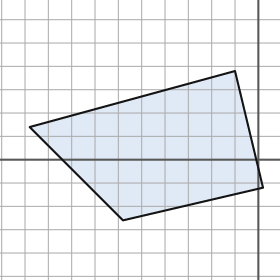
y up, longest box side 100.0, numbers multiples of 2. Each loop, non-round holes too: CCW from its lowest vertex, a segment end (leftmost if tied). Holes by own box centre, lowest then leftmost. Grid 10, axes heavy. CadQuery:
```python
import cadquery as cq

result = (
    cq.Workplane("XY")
    .moveTo(-58.0, -26.0)
    .lineTo(2.0, -12.0)
    .lineTo(-10.0, 38.0)
    .lineTo(-98.0, 14.0)
    .close()
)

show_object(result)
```